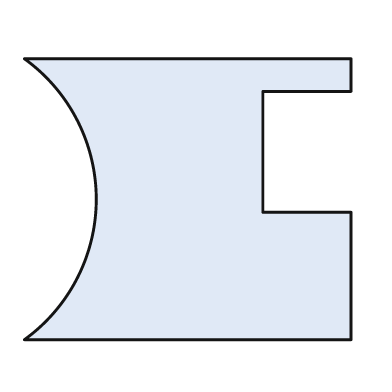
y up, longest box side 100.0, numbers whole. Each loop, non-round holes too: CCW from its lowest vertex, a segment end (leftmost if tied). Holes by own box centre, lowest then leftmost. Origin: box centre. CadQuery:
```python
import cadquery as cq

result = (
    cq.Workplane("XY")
    .moveTo(-50.0, -43.0)
    .lineTo(50.0, -43.0)
    .lineTo(50.0, -4.0)
    .lineTo(23.0, -4.0)
    .lineTo(23.0, 33.0)
    .lineTo(50.0, 33.0)
    .lineTo(50.0, 43.0)
    .lineTo(-50.0, 43.0)
    .threePointArc((-28.0, 0.0), (-50.0, -43.0))
    .close()
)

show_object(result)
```